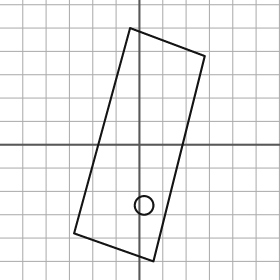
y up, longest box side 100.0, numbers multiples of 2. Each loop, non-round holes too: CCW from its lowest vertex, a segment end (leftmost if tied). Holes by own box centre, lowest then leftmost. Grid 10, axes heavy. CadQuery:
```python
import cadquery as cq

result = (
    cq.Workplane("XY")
    .moveTo(6.0, -50.0)
    .lineTo(28.0, 38.0)
    .lineTo(-4.0, 50.0)
    .lineTo(-28.0, -38.0)
    .close()
    .moveTo(2.0, -26.0)
    .circle(4.0)
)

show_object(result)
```